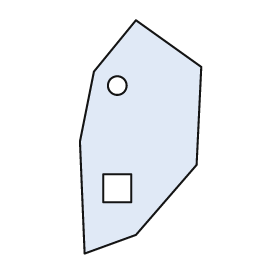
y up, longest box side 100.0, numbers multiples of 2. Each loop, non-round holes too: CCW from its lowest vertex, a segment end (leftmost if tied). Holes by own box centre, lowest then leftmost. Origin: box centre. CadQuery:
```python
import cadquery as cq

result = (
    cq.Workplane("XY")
    .moveTo(-24.0, -50.0)
    .lineTo(-2.0, -42.0)
    .lineTo(24.0, -12.0)
    .lineTo(26.0, 30.0)
    .lineTo(-2.0, 50.0)
    .lineTo(-20.0, 28.0)
    .lineTo(-26.0, -2.0)
    .close()
    .moveTo(-16.0, -28.0)
    .lineTo(-4.0, -28.0)
    .lineTo(-4.0, -16.0)
    .lineTo(-16.0, -16.0)
    .close()
    .moveTo(-10.0, 22.0)
    .circle(4.0)
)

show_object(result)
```